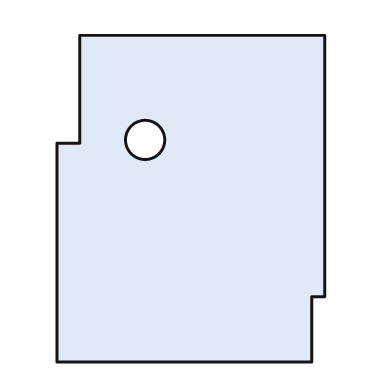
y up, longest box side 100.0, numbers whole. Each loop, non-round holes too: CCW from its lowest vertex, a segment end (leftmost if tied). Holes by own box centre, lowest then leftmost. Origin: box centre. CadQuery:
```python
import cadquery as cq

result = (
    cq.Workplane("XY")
    .moveTo(-41.0, -50.0)
    .lineTo(37.0, -50.0)
    .lineTo(37.0, -30.0)
    .lineTo(41.0, -30.0)
    .lineTo(41.0, 50.0)
    .lineTo(-34.0, 50.0)
    .lineTo(-34.0, 17.0)
    .lineTo(-41.0, 17.0)
    .close()
    .moveTo(-14.0, 18.0)
    .circle(6.0)
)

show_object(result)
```